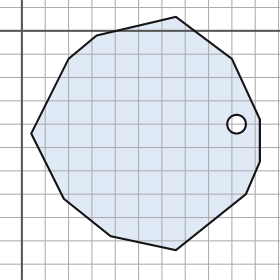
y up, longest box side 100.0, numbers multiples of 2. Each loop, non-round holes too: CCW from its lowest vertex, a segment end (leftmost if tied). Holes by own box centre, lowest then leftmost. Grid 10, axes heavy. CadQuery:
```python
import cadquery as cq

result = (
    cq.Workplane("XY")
    .moveTo(66.0, -94.0)
    .lineTo(96.0, -70.0)
    .lineTo(102.0, -56.0)
    .lineTo(102.0, -38.0)
    .lineTo(90.0, -12.0)
    .lineTo(66.0, 6.0)
    .lineTo(32.0, -2.0)
    .lineTo(20.0, -12.0)
    .lineTo(4.0, -44.0)
    .lineTo(18.0, -72.0)
    .lineTo(38.0, -88.0)
    .close()
    .moveTo(92.0, -40.0)
    .circle(4.0)
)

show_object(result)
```